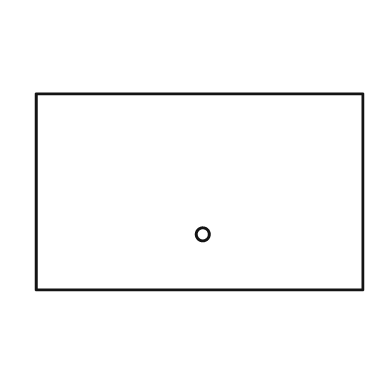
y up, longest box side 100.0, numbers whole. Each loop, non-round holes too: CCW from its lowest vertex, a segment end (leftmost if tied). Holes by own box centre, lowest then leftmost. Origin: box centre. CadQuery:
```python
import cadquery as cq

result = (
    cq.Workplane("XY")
    .moveTo(-50.0, -30.0)
    .lineTo(50.0, -30.0)
    .lineTo(50.0, 30.0)
    .lineTo(-50.0, 30.0)
    .close()
    .moveTo(1.0, -13.0)
    .circle(2.0)
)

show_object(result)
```